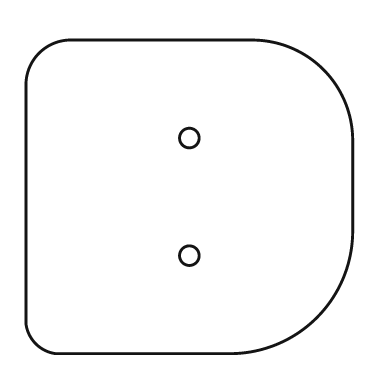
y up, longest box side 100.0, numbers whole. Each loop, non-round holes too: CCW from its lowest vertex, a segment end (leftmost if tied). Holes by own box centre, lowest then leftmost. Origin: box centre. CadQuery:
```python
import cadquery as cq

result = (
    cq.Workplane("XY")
    .moveTo(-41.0, -48.0)
    .lineTo(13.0, -48.0)
    .threePointArc((39.0, -37.0), (50.0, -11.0))
    .lineTo(50.0, 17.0)
    .threePointArc((41.0, 39.0), (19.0, 48.0))
    .lineTo(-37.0, 48.0)
    .threePointArc((-46.0, 44.0), (-50.0, 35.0))
    .lineTo(-50.0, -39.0)
    .threePointArc((-47.0, -45.0), (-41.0, -48.0))
    .close()
    .moveTo(0.0, -18.0)
    .circle(3.0)
    .moveTo(0.0, 18.0)
    .circle(3.0)
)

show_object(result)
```